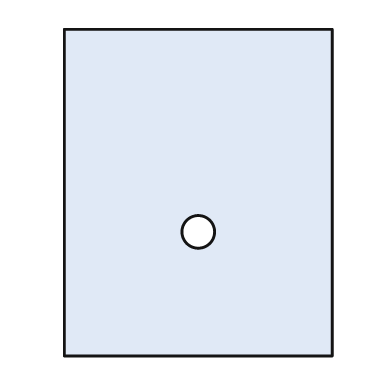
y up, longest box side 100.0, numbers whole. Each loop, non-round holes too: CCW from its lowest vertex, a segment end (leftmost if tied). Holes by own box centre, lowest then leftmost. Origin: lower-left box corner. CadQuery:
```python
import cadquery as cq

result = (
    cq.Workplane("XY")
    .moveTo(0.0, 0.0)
    .lineTo(82.0, 0.0)
    .lineTo(82.0, 100.0)
    .lineTo(0.0, 100.0)
    .close()
    .moveTo(41.0, 38.0)
    .circle(5.0)
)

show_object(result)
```